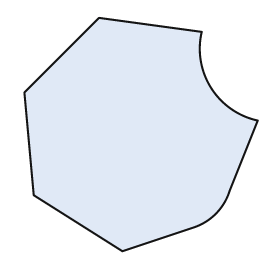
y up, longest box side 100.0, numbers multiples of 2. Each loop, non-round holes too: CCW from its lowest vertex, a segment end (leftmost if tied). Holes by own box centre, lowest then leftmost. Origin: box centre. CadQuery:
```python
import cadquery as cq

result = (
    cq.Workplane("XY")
    .moveTo(-8.0, -50.0)
    .lineTo(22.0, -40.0)
    .threePointArc((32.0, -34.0), (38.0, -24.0))
    .lineTo(50.0, 6.0)
    .threePointArc((30.0, 20.0), (26.0, 44.0))
    .lineTo(-18.0, 50.0)
    .lineTo(-50.0, 18.0)
    .lineTo(-46.0, -26.0)
    .close()
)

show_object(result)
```